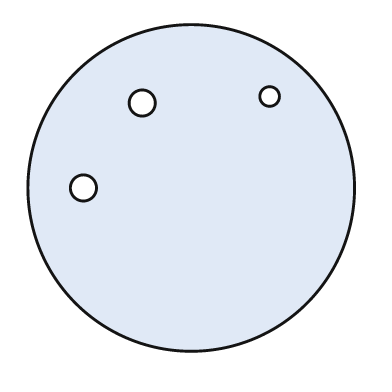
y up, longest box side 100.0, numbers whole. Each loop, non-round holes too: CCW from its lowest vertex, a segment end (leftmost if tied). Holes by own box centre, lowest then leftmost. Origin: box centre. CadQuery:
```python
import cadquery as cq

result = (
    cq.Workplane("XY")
    .moveTo(0.0, 0.0)
    .circle(50.0)
    .moveTo(-33.0, 0.0)
    .circle(4.0)
    .moveTo(-15.0, 26.0)
    .circle(4.0)
    .moveTo(24.0, 28.0)
    .circle(3.0)
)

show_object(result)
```